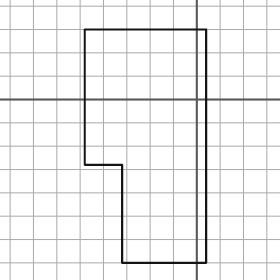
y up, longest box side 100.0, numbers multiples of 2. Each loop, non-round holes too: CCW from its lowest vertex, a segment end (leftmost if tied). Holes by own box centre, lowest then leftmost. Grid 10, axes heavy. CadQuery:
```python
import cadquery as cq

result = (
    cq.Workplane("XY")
    .moveTo(-32.0, -70.0)
    .lineTo(4.0, -70.0)
    .lineTo(4.0, 30.0)
    .lineTo(-48.0, 30.0)
    .lineTo(-48.0, -28.0)
    .lineTo(-32.0, -28.0)
    .close()
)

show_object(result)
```